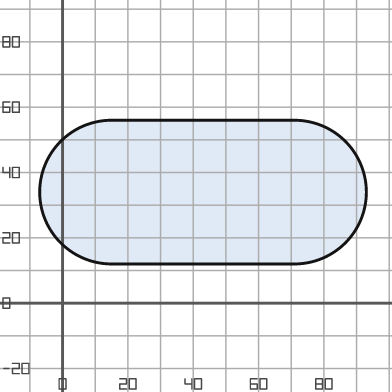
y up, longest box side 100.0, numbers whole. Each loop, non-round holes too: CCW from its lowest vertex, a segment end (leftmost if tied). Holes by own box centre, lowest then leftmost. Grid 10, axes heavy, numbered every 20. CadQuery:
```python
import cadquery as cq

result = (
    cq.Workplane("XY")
    .moveTo(15.0, 12.0)
    .lineTo(71.0, 12.0)
    .threePointArc((93.0, 34.0), (71.0, 56.0))
    .lineTo(15.0, 56.0)
    .threePointArc((-7.0, 34.0), (15.0, 12.0))
    .close()
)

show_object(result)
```